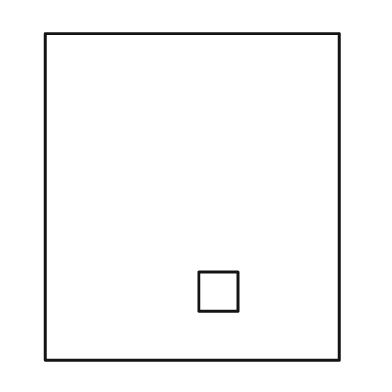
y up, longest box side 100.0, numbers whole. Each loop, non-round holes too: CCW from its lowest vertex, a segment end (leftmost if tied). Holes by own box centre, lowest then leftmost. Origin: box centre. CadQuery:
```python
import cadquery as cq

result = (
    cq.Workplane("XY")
    .moveTo(-45.0, -50.0)
    .lineTo(45.0, -50.0)
    .lineTo(45.0, 50.0)
    .lineTo(-45.0, 50.0)
    .close()
    .moveTo(2.0, -35.0)
    .lineTo(14.0, -35.0)
    .lineTo(14.0, -23.0)
    .lineTo(2.0, -23.0)
    .close()
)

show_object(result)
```